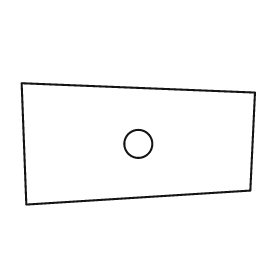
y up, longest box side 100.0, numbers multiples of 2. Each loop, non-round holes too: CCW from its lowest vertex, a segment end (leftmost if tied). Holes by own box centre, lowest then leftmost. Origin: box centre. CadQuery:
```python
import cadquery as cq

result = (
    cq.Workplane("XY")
    .moveTo(-48.0, -26.0)
    .lineTo(48.0, -20.0)
    .lineTo(50.0, 22.0)
    .lineTo(-50.0, 26.0)
    .close()
    .moveTo(0.0, 0.0)
    .circle(6.0)
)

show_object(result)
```